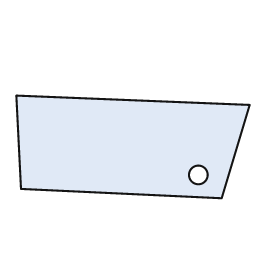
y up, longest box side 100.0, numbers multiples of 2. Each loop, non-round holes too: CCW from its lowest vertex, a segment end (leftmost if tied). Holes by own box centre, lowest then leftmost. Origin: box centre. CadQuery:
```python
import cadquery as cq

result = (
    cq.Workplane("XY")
    .moveTo(38.0, -22.0)
    .lineTo(50.0, 18.0)
    .lineTo(-50.0, 22.0)
    .lineTo(-48.0, -18.0)
    .close()
    .moveTo(28.0, -12.0)
    .circle(4.0)
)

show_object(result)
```